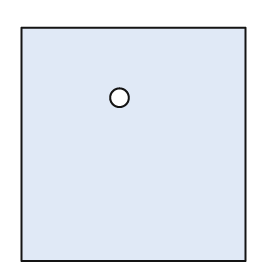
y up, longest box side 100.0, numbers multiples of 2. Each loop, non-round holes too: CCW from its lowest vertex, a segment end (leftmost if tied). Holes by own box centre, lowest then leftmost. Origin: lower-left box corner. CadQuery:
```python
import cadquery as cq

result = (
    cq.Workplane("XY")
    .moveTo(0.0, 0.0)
    .lineTo(96.0, 0.0)
    .lineTo(96.0, 100.0)
    .lineTo(0.0, 100.0)
    .close()
    .moveTo(42.0, 70.0)
    .circle(4.0)
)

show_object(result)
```